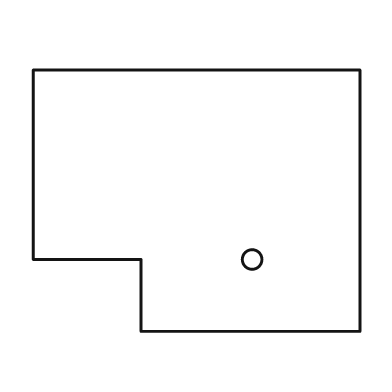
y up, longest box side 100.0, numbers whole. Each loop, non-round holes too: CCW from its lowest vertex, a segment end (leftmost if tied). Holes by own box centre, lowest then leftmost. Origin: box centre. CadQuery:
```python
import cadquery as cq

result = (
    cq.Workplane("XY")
    .moveTo(-17.0, -40.0)
    .lineTo(50.0, -40.0)
    .lineTo(50.0, 40.0)
    .lineTo(-50.0, 40.0)
    .lineTo(-50.0, -18.0)
    .lineTo(-17.0, -18.0)
    .close()
    .moveTo(17.0, -18.0)
    .circle(3.0)
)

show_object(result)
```